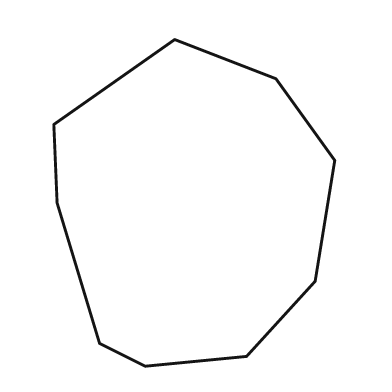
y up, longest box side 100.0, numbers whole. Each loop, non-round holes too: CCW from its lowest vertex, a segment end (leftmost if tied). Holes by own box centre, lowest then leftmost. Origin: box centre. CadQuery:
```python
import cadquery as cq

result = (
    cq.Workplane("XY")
    .moveTo(-15.0, -50.0)
    .lineTo(16.0, -47.0)
    .lineTo(37.0, -24.0)
    .lineTo(43.0, 13.0)
    .lineTo(25.0, 38.0)
    .lineTo(-6.0, 50.0)
    .lineTo(-43.0, 24.0)
    .lineTo(-42.0, 0.0)
    .lineTo(-29.0, -43.0)
    .close()
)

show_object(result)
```